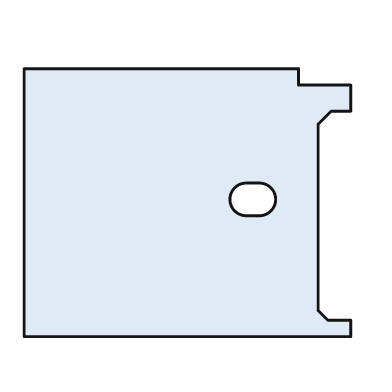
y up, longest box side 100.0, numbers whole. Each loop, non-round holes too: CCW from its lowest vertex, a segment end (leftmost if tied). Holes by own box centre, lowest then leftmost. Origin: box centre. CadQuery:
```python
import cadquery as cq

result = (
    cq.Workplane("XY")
    .moveTo(-50.0, -41.0)
    .lineTo(50.0, -41.0)
    .lineTo(50.0, -36.0)
    .lineTo(43.0, -36.0)
    .lineTo(40.0, -33.0)
    .lineTo(40.0, 24.0)
    .lineTo(44.0, 28.0)
    .lineTo(50.0, 28.0)
    .lineTo(50.0, 36.0)
    .lineTo(34.0, 36.0)
    .lineTo(34.0, 41.0)
    .lineTo(-50.0, 41.0)
    .close()
    .moveTo(18.0, -4.0)
    .lineTo(22.0, -4.0)
    .threePointArc((27.0, 1.0), (22.0, 6.0))
    .lineTo(18.0, 6.0)
    .threePointArc((13.0, 1.0), (18.0, -4.0))
    .close()
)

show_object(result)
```